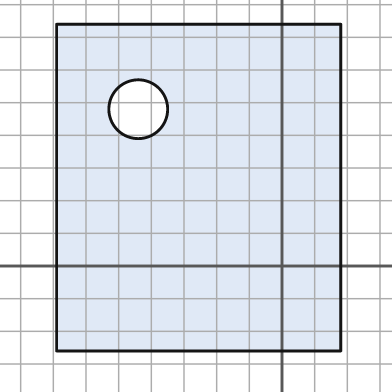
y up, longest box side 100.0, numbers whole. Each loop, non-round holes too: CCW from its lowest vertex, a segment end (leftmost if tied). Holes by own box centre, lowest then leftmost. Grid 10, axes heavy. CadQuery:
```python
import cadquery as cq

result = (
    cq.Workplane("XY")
    .moveTo(-69.0, -26.0)
    .lineTo(18.0, -26.0)
    .lineTo(18.0, 74.0)
    .lineTo(-69.0, 74.0)
    .close()
    .moveTo(-44.0, 48.0)
    .circle(9.0)
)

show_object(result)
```